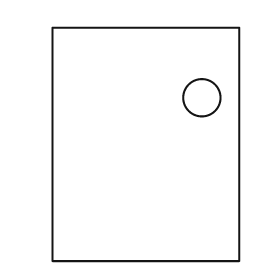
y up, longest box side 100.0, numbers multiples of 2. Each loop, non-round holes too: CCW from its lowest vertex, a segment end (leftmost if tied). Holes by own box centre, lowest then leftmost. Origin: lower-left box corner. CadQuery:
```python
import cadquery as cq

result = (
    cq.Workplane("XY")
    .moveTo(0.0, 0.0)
    .lineTo(80.0, 0.0)
    .lineTo(80.0, 100.0)
    .lineTo(0.0, 100.0)
    .close()
    .moveTo(64.0, 70.0)
    .circle(8.0)
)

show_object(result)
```